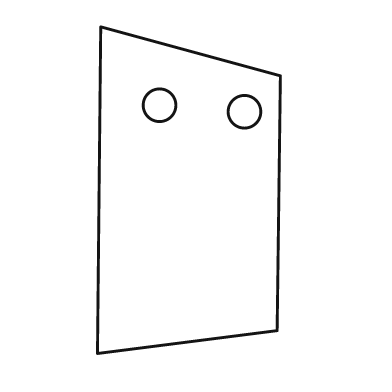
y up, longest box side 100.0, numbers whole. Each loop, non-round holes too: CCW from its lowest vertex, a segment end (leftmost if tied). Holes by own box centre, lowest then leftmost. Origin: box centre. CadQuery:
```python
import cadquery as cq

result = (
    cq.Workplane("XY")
    .moveTo(-28.0, -50.0)
    .lineTo(27.0, -43.0)
    .lineTo(28.0, 35.0)
    .lineTo(-27.0, 50.0)
    .close()
    .moveTo(17.0, 24.0)
    .circle(5.0)
    .moveTo(-9.0, 26.0)
    .circle(5.0)
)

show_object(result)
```